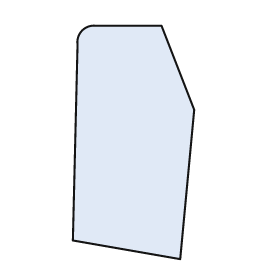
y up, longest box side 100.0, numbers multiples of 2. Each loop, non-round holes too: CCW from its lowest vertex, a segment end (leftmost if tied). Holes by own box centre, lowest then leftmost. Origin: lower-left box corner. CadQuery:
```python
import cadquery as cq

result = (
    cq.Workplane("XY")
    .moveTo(46.0, 0.0)
    .lineTo(52.0, 64.0)
    .lineTo(38.0, 100.0)
    .lineTo(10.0, 100.0)
    .threePointArc((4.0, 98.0), (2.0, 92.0))
    .lineTo(0.0, 8.0)
    .close()
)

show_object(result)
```